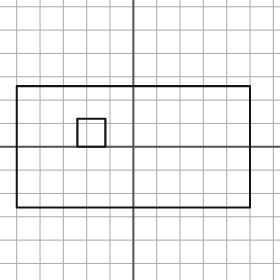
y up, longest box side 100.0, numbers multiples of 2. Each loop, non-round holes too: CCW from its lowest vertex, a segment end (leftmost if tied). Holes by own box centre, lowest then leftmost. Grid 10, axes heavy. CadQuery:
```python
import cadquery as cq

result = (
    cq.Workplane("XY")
    .moveTo(-50.0, -26.0)
    .lineTo(50.0, -26.0)
    .lineTo(50.0, 26.0)
    .lineTo(-50.0, 26.0)
    .close()
    .moveTo(-24.0, 0.0)
    .lineTo(-12.0, 0.0)
    .lineTo(-12.0, 12.0)
    .lineTo(-24.0, 12.0)
    .close()
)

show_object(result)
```